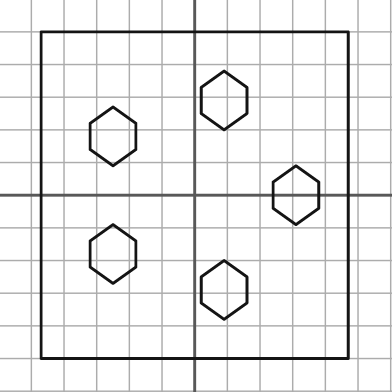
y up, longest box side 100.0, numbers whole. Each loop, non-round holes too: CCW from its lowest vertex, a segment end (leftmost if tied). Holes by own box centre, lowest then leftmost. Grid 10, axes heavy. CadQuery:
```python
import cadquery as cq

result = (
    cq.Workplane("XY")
    .moveTo(-47.0, -50.0)
    .lineTo(47.0, -50.0)
    .lineTo(47.0, 50.0)
    .lineTo(-47.0, 50.0)
    .close()
    .moveTo(9.0, -38.0)
    .lineTo(16.0, -33.0)
    .lineTo(16.0, -25.0)
    .lineTo(9.0, -20.0)
    .lineTo(2.0, -25.0)
    .lineTo(2.0, -33.0)
    .close()
    .moveTo(-25.0, -27.0)
    .lineTo(-18.0, -22.0)
    .lineTo(-18.0, -14.0)
    .lineTo(-25.0, -9.0)
    .lineTo(-32.0, -14.0)
    .lineTo(-32.0, -22.0)
    .close()
    .moveTo(31.0, -9.0)
    .lineTo(38.0, -4.0)
    .lineTo(38.0, 4.0)
    .lineTo(31.0, 9.0)
    .lineTo(24.0, 4.0)
    .lineTo(24.0, -4.0)
    .close()
    .moveTo(-25.0, 9.0)
    .lineTo(-18.0, 14.0)
    .lineTo(-18.0, 22.0)
    .lineTo(-25.0, 27.0)
    .lineTo(-32.0, 22.0)
    .lineTo(-32.0, 14.0)
    .close()
    .moveTo(9.0, 20.0)
    .lineTo(16.0, 25.0)
    .lineTo(16.0, 33.0)
    .lineTo(9.0, 38.0)
    .lineTo(2.0, 33.0)
    .lineTo(2.0, 25.0)
    .close()
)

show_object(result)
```